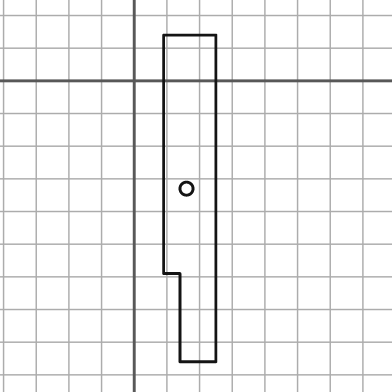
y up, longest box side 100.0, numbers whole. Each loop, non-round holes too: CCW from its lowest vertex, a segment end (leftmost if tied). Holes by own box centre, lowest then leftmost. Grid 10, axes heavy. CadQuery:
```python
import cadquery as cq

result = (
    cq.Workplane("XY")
    .moveTo(14.0, -86.0)
    .lineTo(25.0, -86.0)
    .lineTo(25.0, 14.0)
    .lineTo(9.0, 14.0)
    .lineTo(9.0, -59.0)
    .lineTo(14.0, -59.0)
    .close()
    .moveTo(16.0, -33.0)
    .circle(2.0)
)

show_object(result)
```